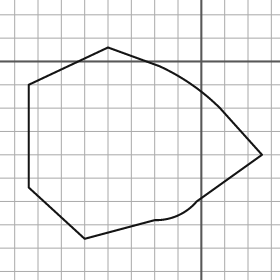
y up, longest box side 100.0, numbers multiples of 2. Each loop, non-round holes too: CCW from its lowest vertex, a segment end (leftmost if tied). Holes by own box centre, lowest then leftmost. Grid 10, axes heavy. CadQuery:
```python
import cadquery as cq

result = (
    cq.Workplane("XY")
    .moveTo(-50.0, -76.0)
    .lineTo(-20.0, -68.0)
    .threePointArc((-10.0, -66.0), (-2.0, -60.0))
    .lineTo(26.0, -40.0)
    .lineTo(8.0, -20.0)
    .threePointArc((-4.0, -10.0), (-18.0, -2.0))
    .lineTo(-40.0, 6.0)
    .lineTo(-74.0, -10.0)
    .lineTo(-74.0, -54.0)
    .close()
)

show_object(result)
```